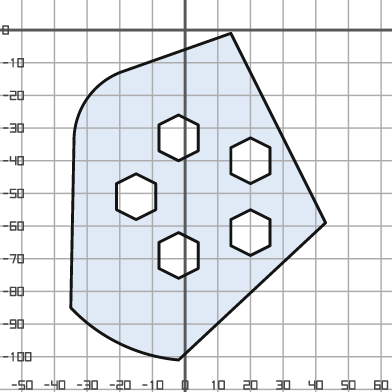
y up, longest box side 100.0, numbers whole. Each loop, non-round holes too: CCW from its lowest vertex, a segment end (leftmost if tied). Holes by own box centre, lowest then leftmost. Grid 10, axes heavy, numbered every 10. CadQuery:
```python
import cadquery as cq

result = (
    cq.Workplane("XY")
    .moveTo(-2.0, -101.0)
    .lineTo(43.0, -59.0)
    .lineTo(14.0, -1.0)
    .lineTo(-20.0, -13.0)
    .threePointArc((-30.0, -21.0), (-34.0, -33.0))
    .lineTo(-35.0, -85.0)
    .threePointArc((-20.0, -96.0), (-2.0, -101.0))
    .close()
    .moveTo(-2.0, -76.0)
    .lineTo(4.0, -73.0)
    .lineTo(4.0, -65.0)
    .lineTo(-2.0, -62.0)
    .lineTo(-8.0, -65.0)
    .lineTo(-8.0, -73.0)
    .close()
    .moveTo(20.0, -69.0)
    .lineTo(26.0, -66.0)
    .lineTo(26.0, -58.0)
    .lineTo(20.0, -55.0)
    .lineTo(14.0, -58.0)
    .lineTo(14.0, -66.0)
    .close()
    .moveTo(-15.0, -58.0)
    .lineTo(-9.0, -55.0)
    .lineTo(-9.0, -47.0)
    .lineTo(-15.0, -44.0)
    .lineTo(-21.0, -47.0)
    .lineTo(-21.0, -55.0)
    .close()
    .moveTo(20.0, -47.0)
    .lineTo(26.0, -44.0)
    .lineTo(26.0, -36.0)
    .lineTo(20.0, -33.0)
    .lineTo(14.0, -36.0)
    .lineTo(14.0, -44.0)
    .close()
    .moveTo(-2.0, -40.0)
    .lineTo(4.0, -37.0)
    .lineTo(4.0, -29.0)
    .lineTo(-2.0, -26.0)
    .lineTo(-8.0, -29.0)
    .lineTo(-8.0, -37.0)
    .close()
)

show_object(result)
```